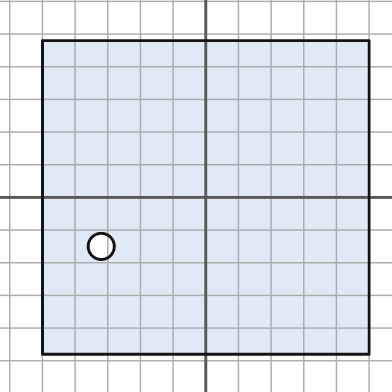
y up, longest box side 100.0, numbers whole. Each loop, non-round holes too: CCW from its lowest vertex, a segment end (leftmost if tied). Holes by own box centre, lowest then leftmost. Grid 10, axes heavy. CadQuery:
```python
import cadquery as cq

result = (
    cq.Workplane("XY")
    .moveTo(-50.0, -48.0)
    .lineTo(50.0, -48.0)
    .lineTo(50.0, 48.0)
    .lineTo(-50.0, 48.0)
    .close()
    .moveTo(-32.0, -15.0)
    .circle(4.0)
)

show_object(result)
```